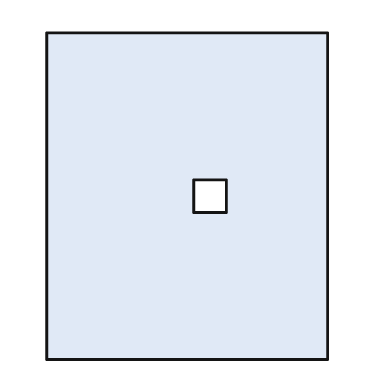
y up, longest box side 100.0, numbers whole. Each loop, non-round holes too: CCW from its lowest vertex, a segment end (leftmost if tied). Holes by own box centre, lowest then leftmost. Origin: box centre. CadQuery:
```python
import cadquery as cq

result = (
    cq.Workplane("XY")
    .moveTo(-43.0, -50.0)
    .lineTo(43.0, -50.0)
    .lineTo(43.0, 50.0)
    .lineTo(-43.0, 50.0)
    .close()
    .moveTo(2.0, -5.0)
    .lineTo(12.0, -5.0)
    .lineTo(12.0, 5.0)
    .lineTo(2.0, 5.0)
    .close()
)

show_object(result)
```